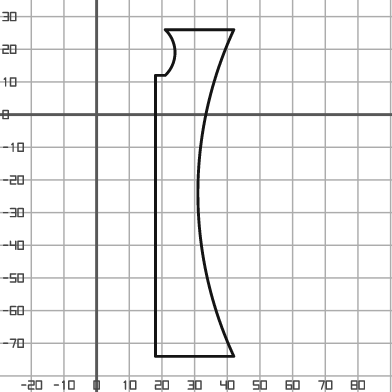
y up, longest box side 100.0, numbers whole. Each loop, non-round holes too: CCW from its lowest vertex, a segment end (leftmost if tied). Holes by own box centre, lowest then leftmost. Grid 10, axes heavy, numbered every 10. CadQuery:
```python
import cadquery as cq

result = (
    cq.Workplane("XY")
    .moveTo(18.0, -74.0)
    .lineTo(42.0, -74.0)
    .threePointArc((31.0, -24.0), (42.0, 26.0))
    .lineTo(21.0, 26.0)
    .threePointArc((24.0, 19.0), (21.0, 12.0))
    .lineTo(18.0, 12.0)
    .close()
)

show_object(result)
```